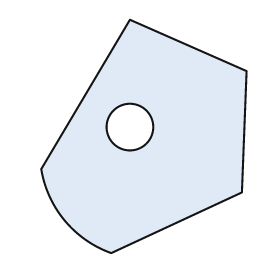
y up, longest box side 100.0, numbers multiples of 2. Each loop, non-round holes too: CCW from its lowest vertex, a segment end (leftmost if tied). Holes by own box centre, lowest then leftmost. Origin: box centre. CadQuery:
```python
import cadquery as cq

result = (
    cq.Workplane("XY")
    .moveTo(-14.0, -50.0)
    .lineTo(42.0, -24.0)
    .lineTo(44.0, 28.0)
    .lineTo(-6.0, 50.0)
    .lineTo(-44.0, -14.0)
    .threePointArc((-34.0, -36.0), (-14.0, -50.0))
    .close()
    .moveTo(-6.0, 4.0)
    .circle(10.0)
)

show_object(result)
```